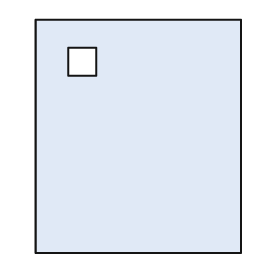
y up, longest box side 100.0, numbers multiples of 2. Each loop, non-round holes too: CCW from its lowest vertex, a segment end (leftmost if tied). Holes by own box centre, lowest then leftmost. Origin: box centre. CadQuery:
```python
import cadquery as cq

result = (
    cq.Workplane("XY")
    .moveTo(-44.0, -50.0)
    .lineTo(44.0, -50.0)
    .lineTo(44.0, 50.0)
    .lineTo(-44.0, 50.0)
    .close()
    .moveTo(-30.0, 26.0)
    .lineTo(-18.0, 26.0)
    .lineTo(-18.0, 38.0)
    .lineTo(-30.0, 38.0)
    .close()
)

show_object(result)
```